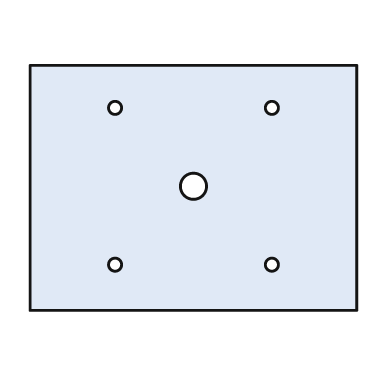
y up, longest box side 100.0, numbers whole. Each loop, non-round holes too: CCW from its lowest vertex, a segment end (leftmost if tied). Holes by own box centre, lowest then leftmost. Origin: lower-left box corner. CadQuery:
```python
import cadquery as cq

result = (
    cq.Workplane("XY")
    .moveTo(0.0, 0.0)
    .lineTo(100.0, 0.0)
    .lineTo(100.0, 75.0)
    .lineTo(0.0, 75.0)
    .close()
    .moveTo(26.0, 14.0)
    .circle(2.0)
    .moveTo(74.0, 14.0)
    .circle(2.0)
    .moveTo(50.0, 38.0)
    .circle(4.0)
    .moveTo(26.0, 62.0)
    .circle(2.0)
    .moveTo(74.0, 62.0)
    .circle(2.0)
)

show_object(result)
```